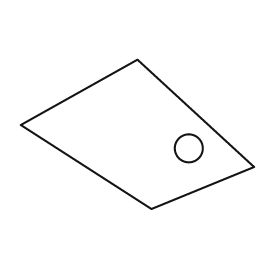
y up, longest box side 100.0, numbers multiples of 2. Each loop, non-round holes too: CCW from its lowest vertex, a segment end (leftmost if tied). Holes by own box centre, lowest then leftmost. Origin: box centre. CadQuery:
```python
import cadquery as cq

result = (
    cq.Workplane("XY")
    .moveTo(6.0, -32.0)
    .lineTo(50.0, -14.0)
    .lineTo(0.0, 32.0)
    .lineTo(-50.0, 4.0)
    .close()
    .moveTo(22.0, -6.0)
    .circle(6.0)
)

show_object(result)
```